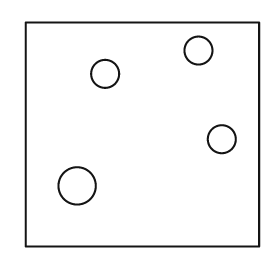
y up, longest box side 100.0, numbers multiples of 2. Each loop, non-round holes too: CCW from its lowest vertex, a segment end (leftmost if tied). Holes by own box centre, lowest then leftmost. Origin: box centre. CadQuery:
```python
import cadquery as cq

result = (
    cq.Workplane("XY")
    .moveTo(-50.0, -48.0)
    .lineTo(50.0, -48.0)
    .lineTo(50.0, 48.0)
    .lineTo(-50.0, 48.0)
    .close()
    .moveTo(-28.0, -22.0)
    .circle(8.0)
    .moveTo(34.0, -2.0)
    .circle(6.0)
    .moveTo(-16.0, 26.0)
    .circle(6.0)
    .moveTo(24.0, 36.0)
    .circle(6.0)
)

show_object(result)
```